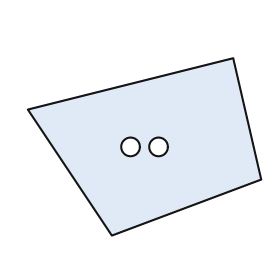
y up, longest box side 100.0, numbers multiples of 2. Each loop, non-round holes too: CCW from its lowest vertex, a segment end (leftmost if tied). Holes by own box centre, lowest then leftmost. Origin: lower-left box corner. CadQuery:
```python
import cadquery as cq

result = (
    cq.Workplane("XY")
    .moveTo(36.0, 0.0)
    .lineTo(100.0, 24.0)
    .lineTo(88.0, 76.0)
    .lineTo(0.0, 54.0)
    .close()
    .moveTo(44.0, 38.0)
    .circle(4.0)
    .moveTo(56.0, 38.0)
    .circle(4.0)
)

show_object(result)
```